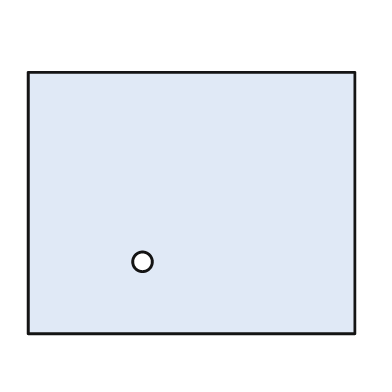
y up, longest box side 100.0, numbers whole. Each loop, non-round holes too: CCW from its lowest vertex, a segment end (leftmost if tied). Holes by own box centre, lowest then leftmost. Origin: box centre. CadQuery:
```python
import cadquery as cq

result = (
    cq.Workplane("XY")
    .moveTo(-50.0, -40.0)
    .lineTo(50.0, -40.0)
    .lineTo(50.0, 40.0)
    .lineTo(-50.0, 40.0)
    .close()
    .moveTo(-15.0, -18.0)
    .circle(3.0)
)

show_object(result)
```